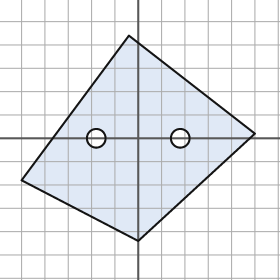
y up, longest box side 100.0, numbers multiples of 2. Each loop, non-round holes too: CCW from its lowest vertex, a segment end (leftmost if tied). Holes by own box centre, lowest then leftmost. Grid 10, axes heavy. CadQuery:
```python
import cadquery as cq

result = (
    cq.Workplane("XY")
    .moveTo(0.0, -44.0)
    .lineTo(50.0, 2.0)
    .lineTo(-4.0, 44.0)
    .lineTo(-50.0, -18.0)
    .close()
    .moveTo(-18.0, 0.0)
    .circle(4.0)
    .moveTo(18.0, 0.0)
    .circle(4.0)
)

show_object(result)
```